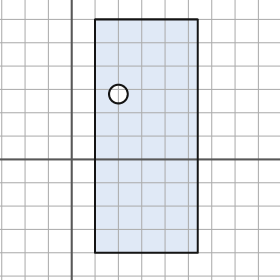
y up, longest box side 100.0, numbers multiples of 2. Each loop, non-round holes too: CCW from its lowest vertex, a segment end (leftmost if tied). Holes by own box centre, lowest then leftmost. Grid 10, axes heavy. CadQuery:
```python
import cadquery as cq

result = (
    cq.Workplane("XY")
    .moveTo(10.0, -40.0)
    .lineTo(54.0, -40.0)
    .lineTo(54.0, 60.0)
    .lineTo(10.0, 60.0)
    .close()
    .moveTo(20.0, 28.0)
    .circle(4.0)
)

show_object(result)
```